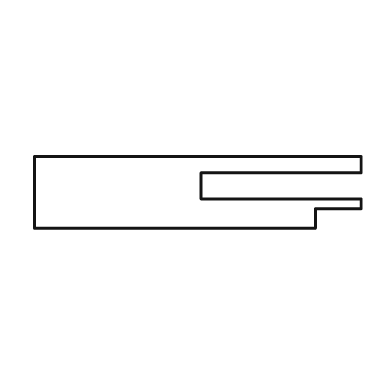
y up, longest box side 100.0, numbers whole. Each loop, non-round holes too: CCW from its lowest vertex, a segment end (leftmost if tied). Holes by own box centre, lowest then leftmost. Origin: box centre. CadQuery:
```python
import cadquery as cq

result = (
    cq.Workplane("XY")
    .moveTo(-50.0, -11.0)
    .lineTo(36.0, -11.0)
    .lineTo(36.0, -5.0)
    .lineTo(50.0, -5.0)
    .lineTo(50.0, -2.0)
    .lineTo(1.0, -2.0)
    .lineTo(1.0, 6.0)
    .lineTo(50.0, 6.0)
    .lineTo(50.0, 11.0)
    .lineTo(-50.0, 11.0)
    .close()
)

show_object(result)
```